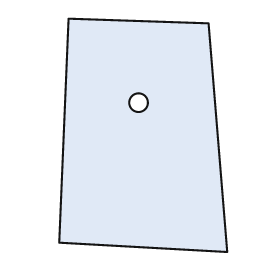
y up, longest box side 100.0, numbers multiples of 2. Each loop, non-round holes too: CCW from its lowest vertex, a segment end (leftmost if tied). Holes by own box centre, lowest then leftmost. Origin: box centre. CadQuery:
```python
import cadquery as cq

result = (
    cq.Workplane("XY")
    .moveTo(36.0, -50.0)
    .lineTo(28.0, 48.0)
    .lineTo(-32.0, 50.0)
    .lineTo(-36.0, -46.0)
    .close()
    .moveTo(-2.0, 14.0)
    .circle(4.0)
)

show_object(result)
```